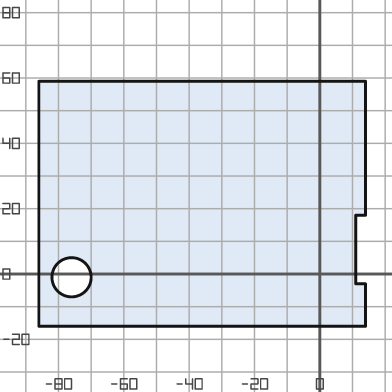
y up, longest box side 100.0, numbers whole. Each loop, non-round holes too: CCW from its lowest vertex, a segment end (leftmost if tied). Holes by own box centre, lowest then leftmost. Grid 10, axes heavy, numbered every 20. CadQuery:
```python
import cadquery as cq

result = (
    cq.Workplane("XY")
    .moveTo(-86.0, -16.0)
    .lineTo(14.0, -16.0)
    .lineTo(14.0, -3.0)
    .lineTo(11.0, -3.0)
    .lineTo(11.0, 18.0)
    .lineTo(14.0, 18.0)
    .lineTo(14.0, 59.0)
    .lineTo(-86.0, 59.0)
    .close()
    .moveTo(-76.0, -1.0)
    .circle(6.0)
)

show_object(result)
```